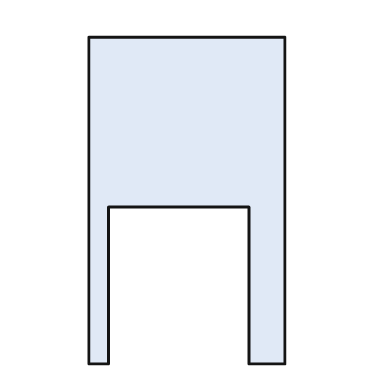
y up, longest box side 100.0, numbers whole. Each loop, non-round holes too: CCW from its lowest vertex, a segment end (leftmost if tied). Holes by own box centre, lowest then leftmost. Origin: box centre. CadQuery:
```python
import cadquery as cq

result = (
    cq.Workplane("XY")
    .moveTo(-30.0, -50.0)
    .lineTo(-24.0, -50.0)
    .lineTo(-24.0, -2.0)
    .lineTo(19.0, -2.0)
    .lineTo(19.0, -50.0)
    .lineTo(30.0, -50.0)
    .lineTo(30.0, 50.0)
    .lineTo(-30.0, 50.0)
    .close()
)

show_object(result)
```